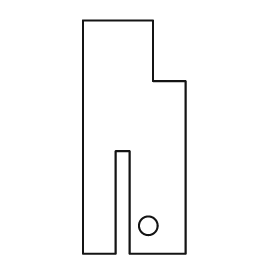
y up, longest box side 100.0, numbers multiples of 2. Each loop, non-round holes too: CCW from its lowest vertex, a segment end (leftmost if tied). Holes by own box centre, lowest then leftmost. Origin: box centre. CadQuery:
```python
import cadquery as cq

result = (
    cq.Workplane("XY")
    .moveTo(-22.0, -50.0)
    .lineTo(-8.0, -50.0)
    .lineTo(-8.0, -6.0)
    .lineTo(-2.0, -6.0)
    .lineTo(-2.0, -50.0)
    .lineTo(22.0, -50.0)
    .lineTo(22.0, 24.0)
    .lineTo(8.0, 24.0)
    .lineTo(8.0, 50.0)
    .lineTo(-22.0, 50.0)
    .close()
    .moveTo(6.0, -38.0)
    .circle(4.0)
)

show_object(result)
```